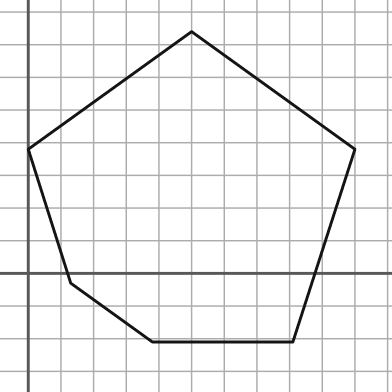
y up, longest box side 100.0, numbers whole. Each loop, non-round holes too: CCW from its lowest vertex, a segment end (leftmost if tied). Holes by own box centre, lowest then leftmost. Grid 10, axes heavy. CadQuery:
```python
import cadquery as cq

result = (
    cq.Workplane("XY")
    .moveTo(38.0, -21.0)
    .lineTo(81.0, -21.0)
    .lineTo(100.0, 38.0)
    .lineTo(50.0, 74.0)
    .lineTo(0.0, 38.0)
    .lineTo(13.0, -3.0)
    .close()
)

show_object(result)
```